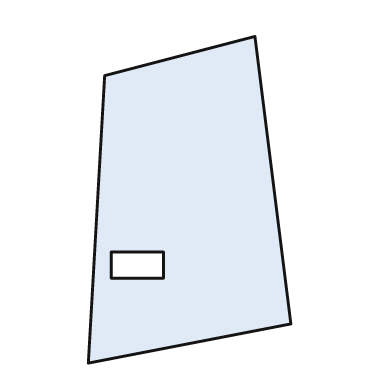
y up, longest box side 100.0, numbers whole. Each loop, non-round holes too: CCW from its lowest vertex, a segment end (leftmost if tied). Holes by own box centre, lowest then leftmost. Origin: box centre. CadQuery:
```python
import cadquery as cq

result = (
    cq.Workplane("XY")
    .moveTo(-31.0, -50.0)
    .lineTo(31.0, -38.0)
    .lineTo(20.0, 50.0)
    .lineTo(-26.0, 38.0)
    .close()
    .moveTo(-24.0, -24.0)
    .lineTo(-8.0, -24.0)
    .lineTo(-8.0, -16.0)
    .lineTo(-24.0, -16.0)
    .close()
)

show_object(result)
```